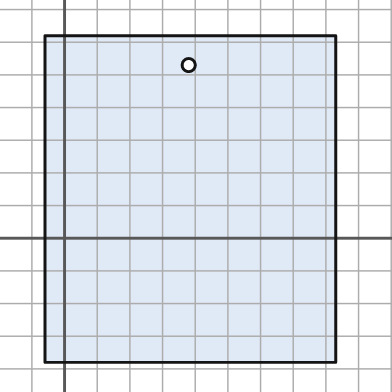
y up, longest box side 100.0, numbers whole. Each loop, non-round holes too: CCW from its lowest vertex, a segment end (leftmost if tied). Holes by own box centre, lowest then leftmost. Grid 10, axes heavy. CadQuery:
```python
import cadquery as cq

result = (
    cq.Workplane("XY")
    .moveTo(-6.0, -38.0)
    .lineTo(83.0, -38.0)
    .lineTo(83.0, 62.0)
    .lineTo(-6.0, 62.0)
    .close()
    .moveTo(38.0, 53.0)
    .circle(2.0)
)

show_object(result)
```